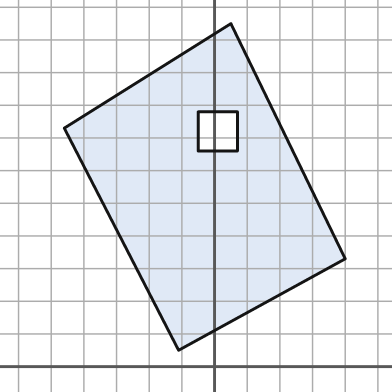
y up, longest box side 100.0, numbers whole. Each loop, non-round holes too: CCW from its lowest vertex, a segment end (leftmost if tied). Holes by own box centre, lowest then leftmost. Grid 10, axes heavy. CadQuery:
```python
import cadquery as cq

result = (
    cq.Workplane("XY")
    .moveTo(-11.0, 5.0)
    .lineTo(40.0, 33.0)
    .lineTo(5.0, 105.0)
    .lineTo(-46.0, 73.0)
    .close()
    .moveTo(-5.0, 66.0)
    .lineTo(7.0, 66.0)
    .lineTo(7.0, 78.0)
    .lineTo(-5.0, 78.0)
    .close()
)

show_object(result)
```